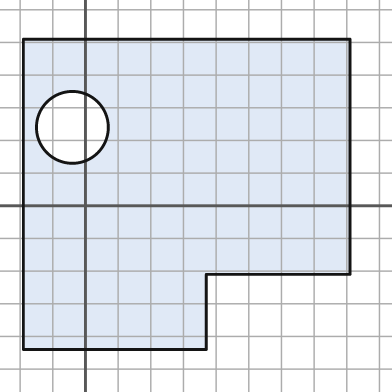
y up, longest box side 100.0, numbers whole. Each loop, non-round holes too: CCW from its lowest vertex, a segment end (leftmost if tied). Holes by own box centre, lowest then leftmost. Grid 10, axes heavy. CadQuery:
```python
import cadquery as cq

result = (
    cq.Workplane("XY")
    .moveTo(-19.0, -44.0)
    .lineTo(37.0, -44.0)
    .lineTo(37.0, -21.0)
    .lineTo(81.0, -21.0)
    .lineTo(81.0, 51.0)
    .lineTo(-19.0, 51.0)
    .close()
    .moveTo(-4.0, 24.0)
    .circle(11.0)
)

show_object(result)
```